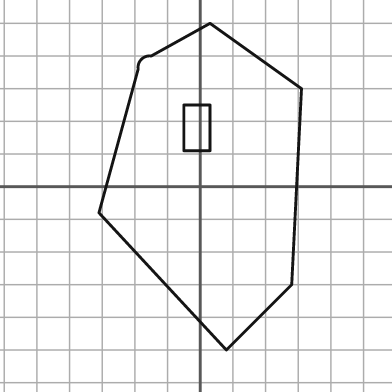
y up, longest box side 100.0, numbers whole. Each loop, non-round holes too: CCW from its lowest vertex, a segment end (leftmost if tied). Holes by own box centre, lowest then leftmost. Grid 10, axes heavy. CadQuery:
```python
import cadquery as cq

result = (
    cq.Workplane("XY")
    .moveTo(8.0, -50.0)
    .lineTo(28.0, -30.0)
    .lineTo(31.0, 30.0)
    .lineTo(3.0, 50.0)
    .lineTo(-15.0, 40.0)
    .threePointArc((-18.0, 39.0), (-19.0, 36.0))
    .lineTo(-31.0, -8.0)
    .close()
    .moveTo(-5.0, 11.0)
    .lineTo(3.0, 11.0)
    .lineTo(3.0, 25.0)
    .lineTo(-5.0, 25.0)
    .close()
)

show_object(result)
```